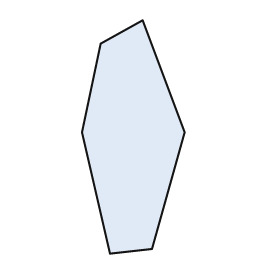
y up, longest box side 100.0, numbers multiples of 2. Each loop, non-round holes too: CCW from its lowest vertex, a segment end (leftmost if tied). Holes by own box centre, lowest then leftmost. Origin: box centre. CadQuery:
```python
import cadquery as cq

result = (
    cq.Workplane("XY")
    .moveTo(-10.0, -50.0)
    .lineTo(8.0, -48.0)
    .lineTo(22.0, 2.0)
    .lineTo(4.0, 50.0)
    .lineTo(-14.0, 40.0)
    .lineTo(-22.0, 2.0)
    .close()
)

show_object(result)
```